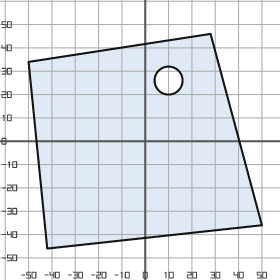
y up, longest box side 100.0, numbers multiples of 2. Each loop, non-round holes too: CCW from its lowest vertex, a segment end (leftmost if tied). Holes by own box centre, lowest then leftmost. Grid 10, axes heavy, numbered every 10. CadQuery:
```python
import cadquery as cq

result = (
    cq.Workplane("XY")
    .moveTo(-42.0, -46.0)
    .lineTo(50.0, -36.0)
    .lineTo(28.0, 46.0)
    .lineTo(-50.0, 34.0)
    .close()
    .moveTo(10.0, 26.0)
    .circle(6.0)
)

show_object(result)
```